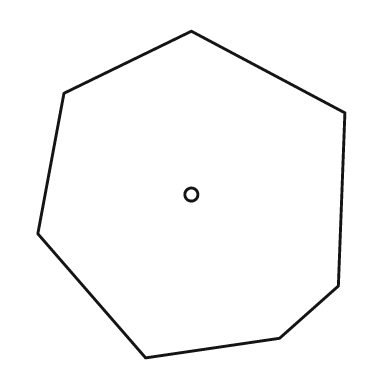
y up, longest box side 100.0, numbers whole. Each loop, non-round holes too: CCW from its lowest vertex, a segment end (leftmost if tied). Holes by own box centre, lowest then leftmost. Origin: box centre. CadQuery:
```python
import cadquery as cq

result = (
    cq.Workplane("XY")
    .moveTo(-14.0, -50.0)
    .lineTo(27.0, -44.0)
    .lineTo(45.0, -28.0)
    .lineTo(47.0, 25.0)
    .lineTo(0.0, 50.0)
    .lineTo(-39.0, 31.0)
    .lineTo(-47.0, -12.0)
    .close()
    .moveTo(0.0, 0.0)
    .circle(2.0)
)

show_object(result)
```